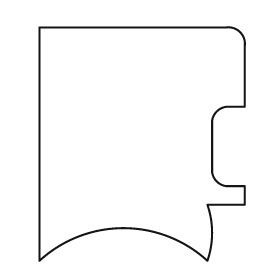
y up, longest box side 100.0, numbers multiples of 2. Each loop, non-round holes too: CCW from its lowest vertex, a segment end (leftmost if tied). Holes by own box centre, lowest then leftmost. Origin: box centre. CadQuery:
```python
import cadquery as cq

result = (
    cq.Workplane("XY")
    .moveTo(-44.0, -50.0)
    .threePointArc((-8.0, -36.0), (28.0, -50.0))
    .threePointArc((30.0, -38.0), (28.0, -26.0))
    .lineTo(44.0, -26.0)
    .lineTo(44.0, -18.0)
    .lineTo(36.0, -18.0)
    .threePointArc((32.0, -16.0), (30.0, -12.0))
    .lineTo(30.0, 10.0)
    .threePointArc((32.0, 14.0), (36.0, 16.0))
    .lineTo(44.0, 16.0)
    .lineTo(44.0, 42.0)
    .threePointArc((42.0, 48.0), (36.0, 50.0))
    .lineTo(-44.0, 50.0)
    .close()
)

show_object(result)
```